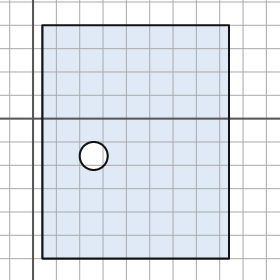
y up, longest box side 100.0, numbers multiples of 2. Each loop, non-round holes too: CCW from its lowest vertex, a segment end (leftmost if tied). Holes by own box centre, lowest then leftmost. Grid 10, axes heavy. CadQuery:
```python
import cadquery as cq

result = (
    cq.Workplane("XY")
    .moveTo(4.0, -60.0)
    .lineTo(84.0, -60.0)
    .lineTo(84.0, 40.0)
    .lineTo(4.0, 40.0)
    .close()
    .moveTo(26.0, -16.0)
    .circle(6.0)
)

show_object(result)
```